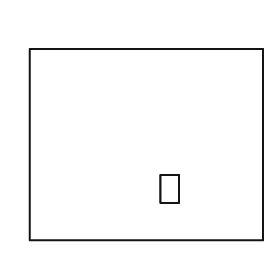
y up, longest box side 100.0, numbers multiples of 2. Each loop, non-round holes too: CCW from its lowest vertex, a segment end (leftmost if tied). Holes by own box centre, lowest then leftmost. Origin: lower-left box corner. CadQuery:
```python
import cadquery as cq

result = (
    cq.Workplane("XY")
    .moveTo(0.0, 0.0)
    .lineTo(100.0, 0.0)
    .lineTo(100.0, 82.0)
    .lineTo(0.0, 82.0)
    .close()
    .moveTo(56.0, 16.0)
    .lineTo(64.0, 16.0)
    .lineTo(64.0, 28.0)
    .lineTo(56.0, 28.0)
    .close()
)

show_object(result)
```